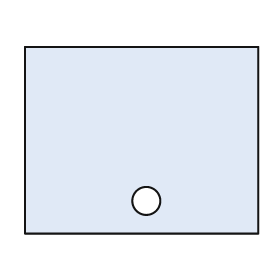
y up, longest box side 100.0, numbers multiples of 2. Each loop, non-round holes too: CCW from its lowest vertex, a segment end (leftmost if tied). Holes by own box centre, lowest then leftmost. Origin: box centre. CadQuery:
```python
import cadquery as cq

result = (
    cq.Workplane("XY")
    .moveTo(-50.0, -40.0)
    .lineTo(50.0, -40.0)
    .lineTo(50.0, 40.0)
    .lineTo(-50.0, 40.0)
    .close()
    .moveTo(2.0, -26.0)
    .circle(6.0)
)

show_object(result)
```